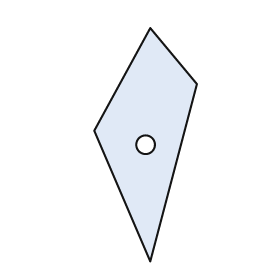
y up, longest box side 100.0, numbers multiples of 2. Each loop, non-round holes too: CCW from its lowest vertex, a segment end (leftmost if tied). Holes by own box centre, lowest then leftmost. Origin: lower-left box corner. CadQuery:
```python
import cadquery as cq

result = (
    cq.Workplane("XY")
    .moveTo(24.0, 0.0)
    .lineTo(44.0, 76.0)
    .lineTo(24.0, 100.0)
    .lineTo(0.0, 56.0)
    .close()
    .moveTo(22.0, 50.0)
    .circle(4.0)
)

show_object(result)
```